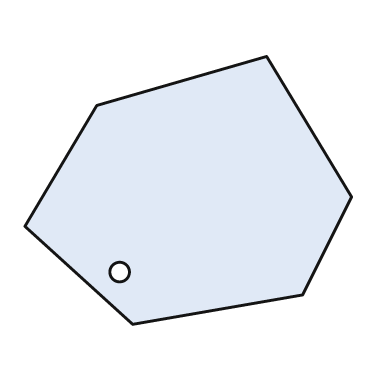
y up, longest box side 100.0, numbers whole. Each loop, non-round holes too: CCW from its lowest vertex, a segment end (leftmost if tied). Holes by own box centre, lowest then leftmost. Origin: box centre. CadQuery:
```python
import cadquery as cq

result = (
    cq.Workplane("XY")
    .moveTo(-17.0, -41.0)
    .lineTo(35.0, -32.0)
    .lineTo(50.0, -2.0)
    .lineTo(24.0, 41.0)
    .lineTo(-28.0, 26.0)
    .lineTo(-50.0, -11.0)
    .close()
    .moveTo(-21.0, -25.0)
    .circle(3.0)
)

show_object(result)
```